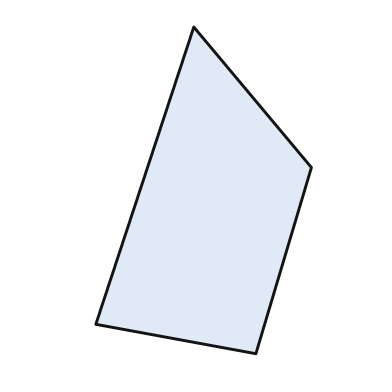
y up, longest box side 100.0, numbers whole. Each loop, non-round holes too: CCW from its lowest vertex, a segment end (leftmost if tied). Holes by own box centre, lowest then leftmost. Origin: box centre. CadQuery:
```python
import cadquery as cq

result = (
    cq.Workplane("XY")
    .moveTo(16.0, -50.0)
    .lineTo(33.0, 7.0)
    .lineTo(-3.0, 50.0)
    .lineTo(-33.0, -41.0)
    .close()
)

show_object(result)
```